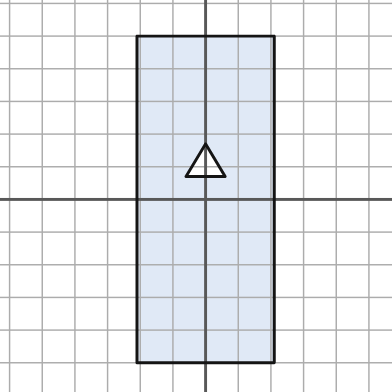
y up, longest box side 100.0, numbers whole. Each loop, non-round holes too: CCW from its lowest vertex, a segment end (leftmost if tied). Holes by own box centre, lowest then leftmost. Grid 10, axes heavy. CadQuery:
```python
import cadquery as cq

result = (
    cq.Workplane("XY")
    .moveTo(-21.0, -50.0)
    .lineTo(21.0, -50.0)
    .lineTo(21.0, 50.0)
    .lineTo(-21.0, 50.0)
    .close()
    .moveTo(-6.0, 7.0)
    .lineTo(6.0, 7.0)
    .lineTo(0.0, 17.0)
    .close()
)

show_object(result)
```